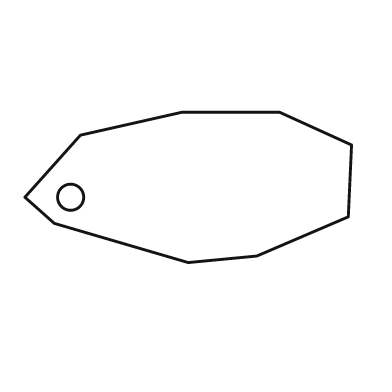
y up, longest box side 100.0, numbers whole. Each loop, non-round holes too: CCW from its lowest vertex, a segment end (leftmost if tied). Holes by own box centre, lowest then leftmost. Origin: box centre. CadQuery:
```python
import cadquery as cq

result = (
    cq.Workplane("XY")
    .moveTo(0.0, -23.0)
    .lineTo(21.0, -21.0)
    .lineTo(49.0, -9.0)
    .lineTo(50.0, 13.0)
    .lineTo(28.0, 23.0)
    .lineTo(-2.0, 23.0)
    .lineTo(-33.0, 16.0)
    .lineTo(-50.0, -3.0)
    .lineTo(-41.0, -11.0)
    .close()
    .moveTo(-36.0, -3.0)
    .circle(4.0)
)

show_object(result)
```